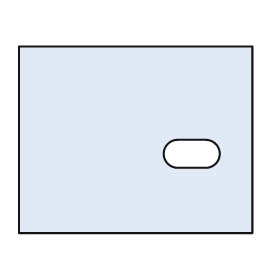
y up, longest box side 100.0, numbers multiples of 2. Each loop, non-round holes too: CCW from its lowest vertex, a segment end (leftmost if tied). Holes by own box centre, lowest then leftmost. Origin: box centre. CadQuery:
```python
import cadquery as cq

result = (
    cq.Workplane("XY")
    .moveTo(-50.0, -40.0)
    .lineTo(50.0, -40.0)
    .lineTo(50.0, 40.0)
    .lineTo(-50.0, 40.0)
    .close()
    .moveTo(18.0, -12.0)
    .lineTo(30.0, -12.0)
    .threePointArc((36.0, -6.0), (30.0, 0.0))
    .lineTo(18.0, 0.0)
    .threePointArc((12.0, -6.0), (18.0, -12.0))
    .close()
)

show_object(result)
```